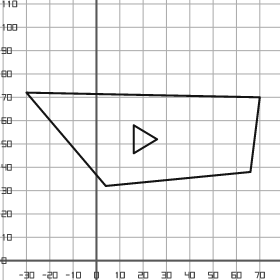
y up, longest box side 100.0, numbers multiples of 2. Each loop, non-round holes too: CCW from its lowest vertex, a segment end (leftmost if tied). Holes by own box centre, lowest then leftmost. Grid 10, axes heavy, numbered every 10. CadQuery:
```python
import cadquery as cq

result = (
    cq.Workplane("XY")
    .moveTo(4.0, 32.0)
    .lineTo(66.0, 38.0)
    .lineTo(70.0, 70.0)
    .lineTo(-30.0, 72.0)
    .close()
    .moveTo(16.0, 46.0)
    .lineTo(26.0, 52.0)
    .lineTo(16.0, 58.0)
    .close()
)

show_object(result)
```